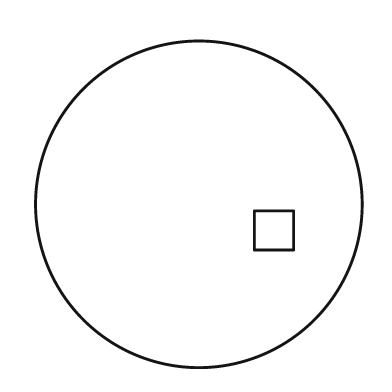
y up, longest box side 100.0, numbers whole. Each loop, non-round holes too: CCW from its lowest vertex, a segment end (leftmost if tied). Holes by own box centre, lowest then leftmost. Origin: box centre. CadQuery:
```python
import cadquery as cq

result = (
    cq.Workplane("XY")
    .moveTo(0.0, 0.0)
    .circle(50.0)
    .moveTo(17.0, -14.0)
    .lineTo(29.0, -14.0)
    .lineTo(29.0, -2.0)
    .lineTo(17.0, -2.0)
    .close()
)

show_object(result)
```